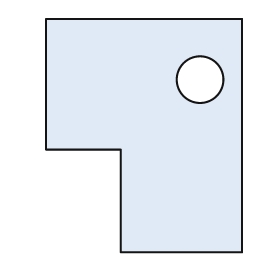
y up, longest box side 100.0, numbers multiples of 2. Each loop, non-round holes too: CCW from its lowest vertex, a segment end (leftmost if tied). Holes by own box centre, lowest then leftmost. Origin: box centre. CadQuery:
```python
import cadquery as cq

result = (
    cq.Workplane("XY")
    .moveTo(-10.0, -50.0)
    .lineTo(42.0, -50.0)
    .lineTo(42.0, 50.0)
    .lineTo(-42.0, 50.0)
    .lineTo(-42.0, -6.0)
    .lineTo(-10.0, -6.0)
    .close()
    .moveTo(24.0, 24.0)
    .circle(10.0)
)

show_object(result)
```